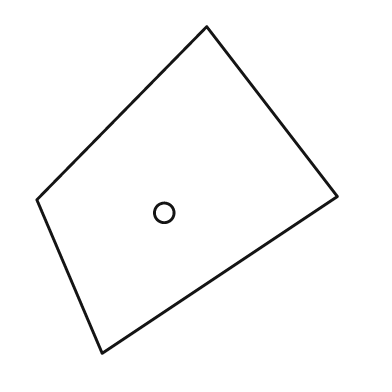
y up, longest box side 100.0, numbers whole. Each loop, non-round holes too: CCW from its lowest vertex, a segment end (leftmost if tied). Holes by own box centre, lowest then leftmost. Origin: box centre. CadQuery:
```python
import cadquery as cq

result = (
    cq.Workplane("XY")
    .moveTo(-26.0, -50.0)
    .lineTo(46.0, -2.0)
    .lineTo(6.0, 50.0)
    .lineTo(-46.0, -3.0)
    .close()
    .moveTo(-7.0, -7.0)
    .circle(3.0)
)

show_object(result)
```